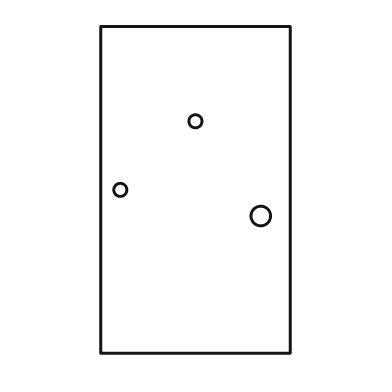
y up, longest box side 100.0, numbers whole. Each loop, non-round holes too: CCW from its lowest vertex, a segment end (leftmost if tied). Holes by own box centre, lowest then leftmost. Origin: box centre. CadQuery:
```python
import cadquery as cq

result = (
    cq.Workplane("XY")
    .moveTo(-29.0, -50.0)
    .lineTo(29.0, -50.0)
    .lineTo(29.0, 50.0)
    .lineTo(-29.0, 50.0)
    .close()
    .moveTo(20.0, -8.0)
    .circle(3.0)
    .moveTo(-23.0, 0.0)
    .circle(2.0)
    .moveTo(0.0, 21.0)
    .circle(2.0)
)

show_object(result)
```